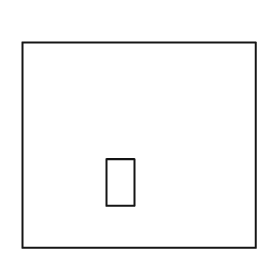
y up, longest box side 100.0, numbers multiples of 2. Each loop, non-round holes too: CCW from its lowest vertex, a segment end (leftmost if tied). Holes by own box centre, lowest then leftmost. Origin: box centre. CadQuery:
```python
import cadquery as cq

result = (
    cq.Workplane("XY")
    .moveTo(-50.0, -44.0)
    .lineTo(50.0, -44.0)
    .lineTo(50.0, 44.0)
    .lineTo(-50.0, 44.0)
    .close()
    .moveTo(-14.0, -26.0)
    .lineTo(-2.0, -26.0)
    .lineTo(-2.0, -6.0)
    .lineTo(-14.0, -6.0)
    .close()
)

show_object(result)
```